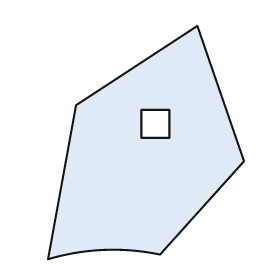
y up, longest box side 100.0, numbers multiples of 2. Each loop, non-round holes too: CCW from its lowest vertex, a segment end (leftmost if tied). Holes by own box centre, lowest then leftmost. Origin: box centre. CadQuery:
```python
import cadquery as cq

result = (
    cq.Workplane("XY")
    .moveTo(-42.0, -50.0)
    .threePointArc((-18.0, -46.0), (6.0, -48.0))
    .lineTo(42.0, -8.0)
    .lineTo(22.0, 50.0)
    .lineTo(-30.0, 16.0)
    .close()
    .moveTo(-2.0, 2.0)
    .lineTo(10.0, 2.0)
    .lineTo(10.0, 14.0)
    .lineTo(-2.0, 14.0)
    .close()
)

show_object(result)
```